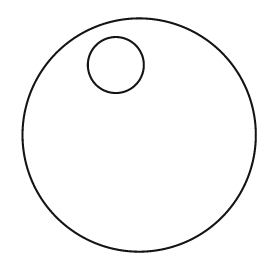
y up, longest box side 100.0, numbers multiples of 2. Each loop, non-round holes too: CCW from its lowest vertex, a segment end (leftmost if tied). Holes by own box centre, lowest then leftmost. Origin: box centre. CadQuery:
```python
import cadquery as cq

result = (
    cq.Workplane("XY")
    .moveTo(0.0, 0.0)
    .circle(50.0)
    .moveTo(-10.0, 30.0)
    .circle(12.0)
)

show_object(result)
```